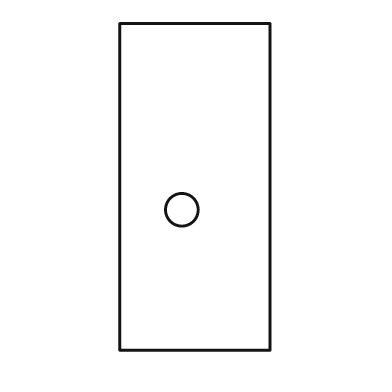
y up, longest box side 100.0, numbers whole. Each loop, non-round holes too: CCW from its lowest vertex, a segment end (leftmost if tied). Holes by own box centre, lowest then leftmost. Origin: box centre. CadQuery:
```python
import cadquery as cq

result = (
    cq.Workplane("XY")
    .moveTo(-23.0, -50.0)
    .lineTo(23.0, -50.0)
    .lineTo(23.0, 50.0)
    .lineTo(-23.0, 50.0)
    .close()
    .moveTo(-4.0, -7.0)
    .circle(5.0)
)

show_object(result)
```